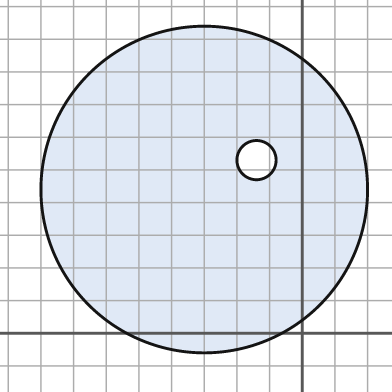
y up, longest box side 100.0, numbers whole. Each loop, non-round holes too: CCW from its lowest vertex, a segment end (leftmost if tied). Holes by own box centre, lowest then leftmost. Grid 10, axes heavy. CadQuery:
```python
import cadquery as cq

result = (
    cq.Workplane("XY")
    .moveTo(-30.0, 44.0)
    .circle(50.0)
    .moveTo(-14.0, 53.0)
    .circle(6.0)
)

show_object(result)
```